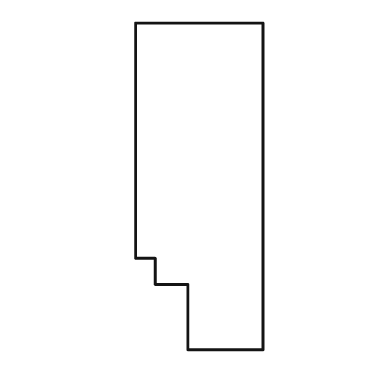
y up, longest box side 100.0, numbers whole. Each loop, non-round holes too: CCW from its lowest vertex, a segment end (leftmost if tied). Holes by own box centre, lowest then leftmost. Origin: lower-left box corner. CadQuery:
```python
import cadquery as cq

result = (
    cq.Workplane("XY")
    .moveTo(16.0, 0.0)
    .lineTo(39.0, 0.0)
    .lineTo(39.0, 100.0)
    .lineTo(0.0, 100.0)
    .lineTo(0.0, 28.0)
    .lineTo(6.0, 28.0)
    .lineTo(6.0, 20.0)
    .lineTo(16.0, 20.0)
    .close()
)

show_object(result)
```